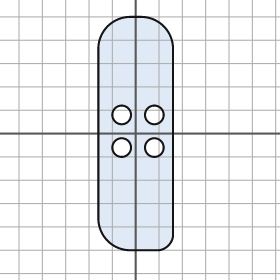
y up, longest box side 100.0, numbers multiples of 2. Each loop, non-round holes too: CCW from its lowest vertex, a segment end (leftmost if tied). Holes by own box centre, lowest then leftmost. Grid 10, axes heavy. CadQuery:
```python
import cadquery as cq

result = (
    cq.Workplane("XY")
    .moveTo(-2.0, -50.0)
    .lineTo(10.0, -50.0)
    .threePointArc((14.0, -48.0), (16.0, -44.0))
    .lineTo(16.0, 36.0)
    .threePointArc((12.0, 46.0), (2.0, 50.0))
    .lineTo(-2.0, 50.0)
    .threePointArc((-12.0, 46.0), (-16.0, 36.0))
    .lineTo(-16.0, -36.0)
    .threePointArc((-12.0, -46.0), (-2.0, -50.0))
    .close()
    .moveTo(-6.0, -6.0)
    .circle(4.0)
    .moveTo(8.0, -6.0)
    .circle(4.0)
    .moveTo(-6.0, 8.0)
    .circle(4.0)
    .moveTo(8.0, 8.0)
    .circle(4.0)
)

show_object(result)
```